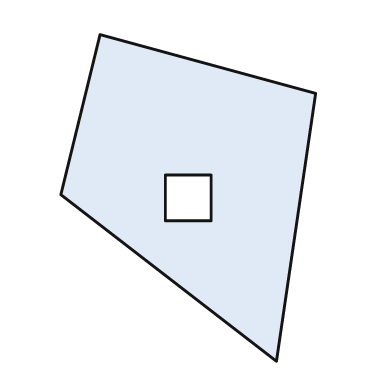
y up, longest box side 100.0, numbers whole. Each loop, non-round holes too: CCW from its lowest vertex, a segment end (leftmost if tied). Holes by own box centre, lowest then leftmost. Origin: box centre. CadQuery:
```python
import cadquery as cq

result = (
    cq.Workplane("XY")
    .moveTo(27.0, -50.0)
    .lineTo(39.0, 32.0)
    .lineTo(-27.0, 50.0)
    .lineTo(-39.0, 1.0)
    .close()
    .moveTo(-7.0, -7.0)
    .lineTo(7.0, -7.0)
    .lineTo(7.0, 7.0)
    .lineTo(-7.0, 7.0)
    .close()
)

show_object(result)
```